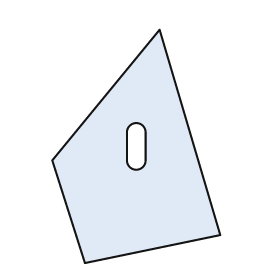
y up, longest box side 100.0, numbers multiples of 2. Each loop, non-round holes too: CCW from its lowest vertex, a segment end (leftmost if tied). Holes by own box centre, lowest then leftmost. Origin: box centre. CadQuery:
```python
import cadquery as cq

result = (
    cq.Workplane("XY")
    .moveTo(-22.0, -50.0)
    .lineTo(36.0, -38.0)
    .lineTo(10.0, 50.0)
    .lineTo(-36.0, -6.0)
    .close()
    .moveTo(-4.0, -6.0)
    .threePointArc((0.0, -10.0), (4.0, -6.0))
    .lineTo(4.0, 6.0)
    .threePointArc((0.0, 10.0), (-4.0, 6.0))
    .close()
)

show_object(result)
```